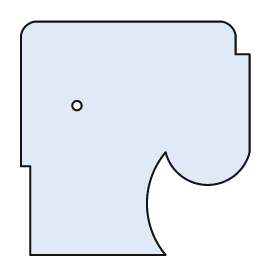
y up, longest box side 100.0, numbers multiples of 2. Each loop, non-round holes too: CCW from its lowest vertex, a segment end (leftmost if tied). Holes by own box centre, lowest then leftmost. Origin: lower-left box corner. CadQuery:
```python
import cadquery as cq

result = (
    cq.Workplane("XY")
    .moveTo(4.0, 0.0)
    .lineTo(62.0, 0.0)
    .threePointArc((54.0, 22.0), (62.0, 44.0))
    .threePointArc((80.0, 30.0), (98.0, 44.0))
    .lineTo(98.0, 86.0)
    .lineTo(92.0, 86.0)
    .lineTo(92.0, 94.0)
    .threePointArc((90.0, 98.0), (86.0, 100.0))
    .lineTo(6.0, 100.0)
    .threePointArc((2.0, 98.0), (0.0, 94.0))
    .lineTo(0.0, 38.0)
    .lineTo(4.0, 38.0)
    .close()
    .moveTo(24.0, 64.0)
    .circle(2.0)
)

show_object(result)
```